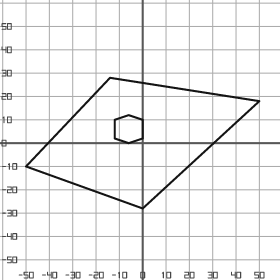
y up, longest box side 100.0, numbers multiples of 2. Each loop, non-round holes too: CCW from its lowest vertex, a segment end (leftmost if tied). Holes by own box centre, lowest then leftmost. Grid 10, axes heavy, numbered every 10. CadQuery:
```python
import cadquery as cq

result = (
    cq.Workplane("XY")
    .moveTo(0.0, -28.0)
    .lineTo(50.0, 18.0)
    .lineTo(-14.0, 28.0)
    .lineTo(-50.0, -10.0)
    .close()
    .moveTo(-6.0, 0.0)
    .lineTo(0.0, 2.0)
    .lineTo(0.0, 10.0)
    .lineTo(-6.0, 12.0)
    .lineTo(-12.0, 10.0)
    .lineTo(-12.0, 2.0)
    .close()
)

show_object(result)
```